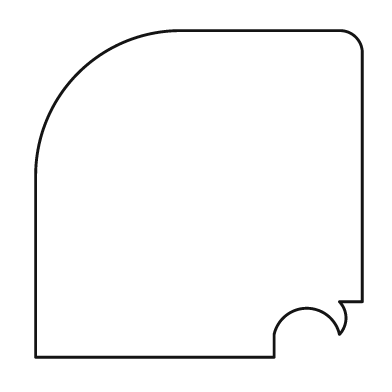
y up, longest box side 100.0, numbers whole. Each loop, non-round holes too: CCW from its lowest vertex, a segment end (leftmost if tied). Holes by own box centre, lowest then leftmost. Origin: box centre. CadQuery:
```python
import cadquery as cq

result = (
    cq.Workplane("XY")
    .moveTo(-50.0, -50.0)
    .lineTo(23.0, -50.0)
    .lineTo(23.0, -43.0)
    .threePointArc((33.0, -35.0), (43.0, -43.0))
    .threePointArc((45.0, -38.0), (43.0, -33.0))
    .lineTo(50.0, -33.0)
    .lineTo(50.0, 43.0)
    .threePointArc((48.0, 48.0), (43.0, 50.0))
    .lineTo(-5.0, 50.0)
    .threePointArc((-37.0, 37.0), (-50.0, 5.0))
    .close()
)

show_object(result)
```